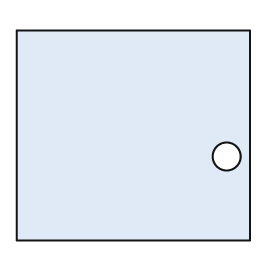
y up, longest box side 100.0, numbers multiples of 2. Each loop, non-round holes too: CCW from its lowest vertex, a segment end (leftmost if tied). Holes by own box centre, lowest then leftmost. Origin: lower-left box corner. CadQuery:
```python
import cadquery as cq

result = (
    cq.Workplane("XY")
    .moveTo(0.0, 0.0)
    .lineTo(100.0, 0.0)
    .lineTo(100.0, 90.0)
    .lineTo(0.0, 90.0)
    .close()
    .moveTo(90.0, 36.0)
    .circle(6.0)
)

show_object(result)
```